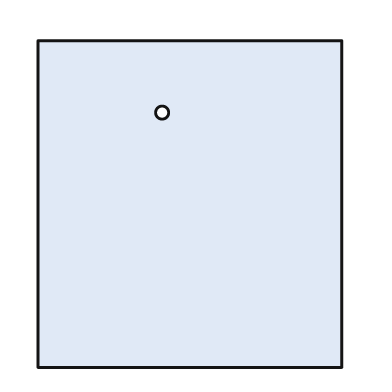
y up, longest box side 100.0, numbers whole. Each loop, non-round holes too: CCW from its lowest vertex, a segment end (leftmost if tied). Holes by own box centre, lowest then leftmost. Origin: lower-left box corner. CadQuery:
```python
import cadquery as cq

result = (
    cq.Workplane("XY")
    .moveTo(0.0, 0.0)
    .lineTo(93.0, 0.0)
    .lineTo(93.0, 100.0)
    .lineTo(0.0, 100.0)
    .close()
    .moveTo(38.0, 78.0)
    .circle(2.0)
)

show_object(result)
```